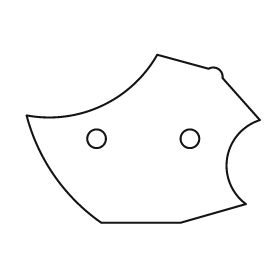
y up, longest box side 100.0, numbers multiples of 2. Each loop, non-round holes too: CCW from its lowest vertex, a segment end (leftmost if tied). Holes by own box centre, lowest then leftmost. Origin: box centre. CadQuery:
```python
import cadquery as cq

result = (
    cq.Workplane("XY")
    .moveTo(-18.0, -36.0)
    .lineTo(16.0, -36.0)
    .lineTo(44.0, -28.0)
    .threePointArc((36.0, -8.0), (50.0, 8.0))
    .lineTo(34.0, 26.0)
    .threePointArc((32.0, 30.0), (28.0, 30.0))
    .lineTo(6.0, 36.0)
    .threePointArc((-18.0, 14.0), (-50.0, 10.0))
    .threePointArc((-38.0, -16.0), (-18.0, -36.0))
    .close()
    .moveTo(-20.0, 0.0)
    .circle(4.0)
    .moveTo(20.0, 0.0)
    .circle(4.0)
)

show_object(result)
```